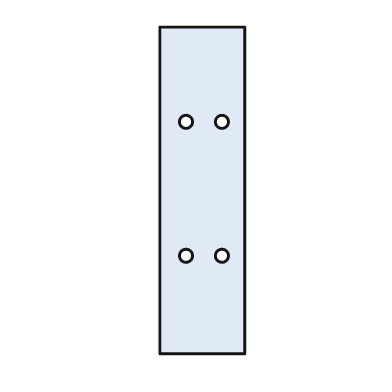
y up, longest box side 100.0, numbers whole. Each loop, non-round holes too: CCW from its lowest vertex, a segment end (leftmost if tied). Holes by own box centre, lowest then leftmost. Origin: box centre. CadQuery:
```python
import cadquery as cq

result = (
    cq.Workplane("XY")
    .moveTo(-13.0, -50.0)
    .lineTo(13.0, -50.0)
    .lineTo(13.0, 50.0)
    .lineTo(-13.0, 50.0)
    .close()
    .moveTo(-5.0, -20.0)
    .circle(2.0)
    .moveTo(6.0, -20.0)
    .circle(2.0)
    .moveTo(-5.0, 21.0)
    .circle(2.0)
    .moveTo(6.0, 21.0)
    .circle(2.0)
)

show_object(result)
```